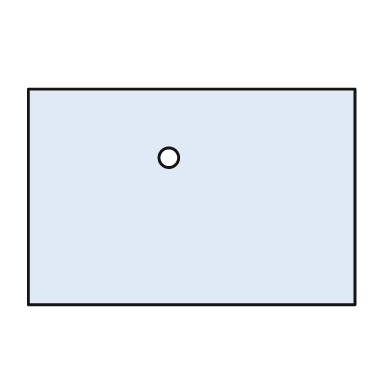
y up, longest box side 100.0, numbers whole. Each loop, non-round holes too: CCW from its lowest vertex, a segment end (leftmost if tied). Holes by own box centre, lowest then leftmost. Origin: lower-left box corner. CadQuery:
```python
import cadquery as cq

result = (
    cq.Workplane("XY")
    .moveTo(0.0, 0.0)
    .lineTo(100.0, 0.0)
    .lineTo(100.0, 66.0)
    .lineTo(0.0, 66.0)
    .close()
    .moveTo(43.0, 45.0)
    .circle(3.0)
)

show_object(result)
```